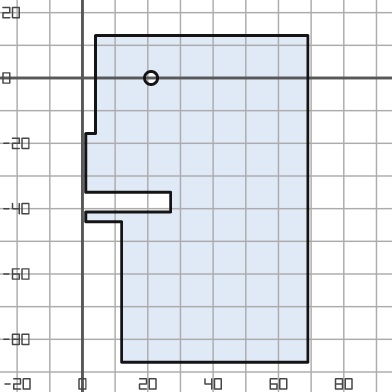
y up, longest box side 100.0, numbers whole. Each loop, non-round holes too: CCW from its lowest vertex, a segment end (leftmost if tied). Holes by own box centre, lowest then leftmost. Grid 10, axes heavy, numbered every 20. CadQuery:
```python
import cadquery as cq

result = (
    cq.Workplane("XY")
    .moveTo(12.0, -87.0)
    .lineTo(69.0, -87.0)
    .lineTo(69.0, 13.0)
    .lineTo(4.0, 13.0)
    .lineTo(4.0, -17.0)
    .lineTo(1.0, -17.0)
    .lineTo(1.0, -35.0)
    .lineTo(27.0, -35.0)
    .lineTo(27.0, -41.0)
    .lineTo(1.0, -41.0)
    .lineTo(1.0, -44.0)
    .lineTo(12.0, -44.0)
    .close()
    .moveTo(21.0, 0.0)
    .circle(2.0)
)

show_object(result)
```